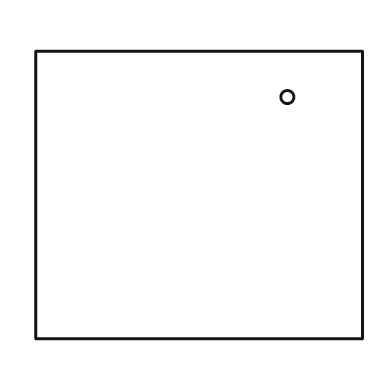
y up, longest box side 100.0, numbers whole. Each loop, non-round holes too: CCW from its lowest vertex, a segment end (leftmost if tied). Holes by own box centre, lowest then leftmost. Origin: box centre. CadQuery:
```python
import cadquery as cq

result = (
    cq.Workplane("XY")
    .moveTo(-50.0, -44.0)
    .lineTo(50.0, -44.0)
    .lineTo(50.0, 44.0)
    .lineTo(-50.0, 44.0)
    .close()
    .moveTo(27.0, 30.0)
    .circle(2.0)
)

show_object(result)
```